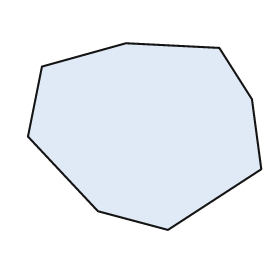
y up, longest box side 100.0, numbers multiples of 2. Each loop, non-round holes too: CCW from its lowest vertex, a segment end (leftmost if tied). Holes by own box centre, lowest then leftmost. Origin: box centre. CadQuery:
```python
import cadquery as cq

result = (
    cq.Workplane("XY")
    .moveTo(10.0, -40.0)
    .lineTo(50.0, -14.0)
    .lineTo(46.0, 16.0)
    .lineTo(32.0, 38.0)
    .lineTo(-8.0, 40.0)
    .lineTo(-44.0, 30.0)
    .lineTo(-50.0, 0.0)
    .lineTo(-20.0, -32.0)
    .close()
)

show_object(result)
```